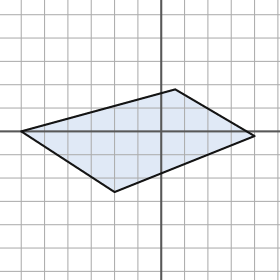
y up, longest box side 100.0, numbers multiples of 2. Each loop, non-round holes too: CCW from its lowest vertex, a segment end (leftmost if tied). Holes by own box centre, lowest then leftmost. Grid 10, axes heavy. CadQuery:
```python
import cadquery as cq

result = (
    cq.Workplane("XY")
    .moveTo(-20.0, -26.0)
    .lineTo(40.0, -2.0)
    .lineTo(6.0, 18.0)
    .lineTo(-60.0, 0.0)
    .close()
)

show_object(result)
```